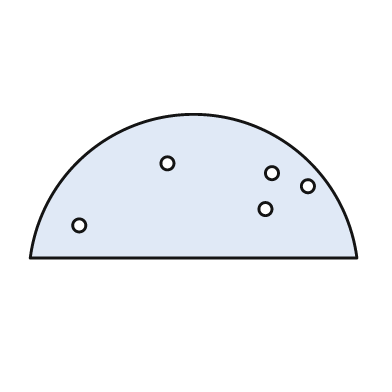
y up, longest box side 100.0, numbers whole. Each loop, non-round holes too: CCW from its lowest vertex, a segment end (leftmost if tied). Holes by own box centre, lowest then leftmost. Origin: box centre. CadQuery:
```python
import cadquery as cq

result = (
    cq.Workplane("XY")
    .moveTo(-50.0, -22.0)
    .lineTo(50.0, -22.0)
    .threePointArc((0.0, 22.0), (-50.0, -22.0))
    .close()
    .moveTo(-35.0, -12.0)
    .circle(2.0)
    .moveTo(22.0, -7.0)
    .circle(2.0)
    .moveTo(35.0, 0.0)
    .circle(2.0)
    .moveTo(24.0, 4.0)
    .circle(2.0)
    .moveTo(-8.0, 7.0)
    .circle(2.0)
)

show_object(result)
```